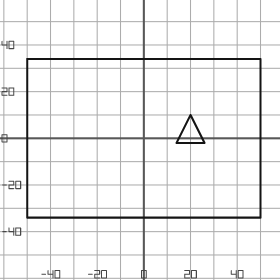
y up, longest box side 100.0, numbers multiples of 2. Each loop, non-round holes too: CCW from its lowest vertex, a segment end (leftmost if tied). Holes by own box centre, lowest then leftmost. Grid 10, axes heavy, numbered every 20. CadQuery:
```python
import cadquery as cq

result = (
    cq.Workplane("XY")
    .moveTo(-50.0, -34.0)
    .lineTo(50.0, -34.0)
    .lineTo(50.0, 34.0)
    .lineTo(-50.0, 34.0)
    .close()
    .moveTo(14.0, -2.0)
    .lineTo(26.0, -2.0)
    .lineTo(20.0, 10.0)
    .close()
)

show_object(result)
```